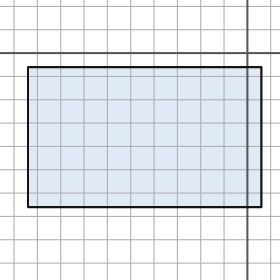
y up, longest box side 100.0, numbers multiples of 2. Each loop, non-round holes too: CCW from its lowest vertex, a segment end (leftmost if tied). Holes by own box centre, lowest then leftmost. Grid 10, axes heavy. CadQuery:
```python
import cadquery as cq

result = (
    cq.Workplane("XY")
    .moveTo(-94.0, -66.0)
    .lineTo(6.0, -66.0)
    .lineTo(6.0, -6.0)
    .lineTo(-94.0, -6.0)
    .close()
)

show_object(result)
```